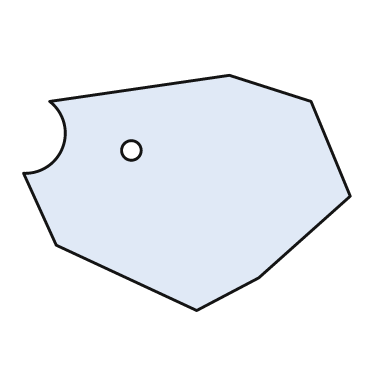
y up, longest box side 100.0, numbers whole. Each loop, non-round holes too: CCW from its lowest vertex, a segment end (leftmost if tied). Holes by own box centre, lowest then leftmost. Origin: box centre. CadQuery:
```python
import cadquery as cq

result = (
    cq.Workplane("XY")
    .moveTo(3.0, -36.0)
    .lineTo(22.0, -26.0)
    .lineTo(50.0, -1.0)
    .lineTo(38.0, 28.0)
    .lineTo(13.0, 36.0)
    .lineTo(-42.0, 28.0)
    .threePointArc((-38.0, 14.0), (-50.0, 6.0))
    .lineTo(-40.0, -16.0)
    .close()
    .moveTo(-17.0, 13.0)
    .circle(3.0)
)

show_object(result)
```